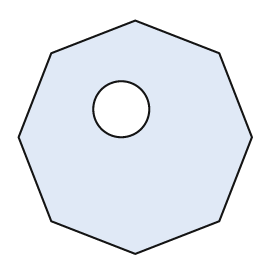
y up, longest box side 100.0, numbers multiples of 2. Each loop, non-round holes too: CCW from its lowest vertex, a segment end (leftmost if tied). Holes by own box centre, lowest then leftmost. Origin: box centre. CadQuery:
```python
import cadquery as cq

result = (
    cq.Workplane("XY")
    .moveTo(0.0, -50.0)
    .lineTo(36.0, -36.0)
    .lineTo(50.0, 0.0)
    .lineTo(36.0, 36.0)
    .lineTo(0.0, 50.0)
    .lineTo(-36.0, 36.0)
    .lineTo(-50.0, 0.0)
    .lineTo(-36.0, -36.0)
    .close()
    .moveTo(-6.0, 12.0)
    .circle(12.0)
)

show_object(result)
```